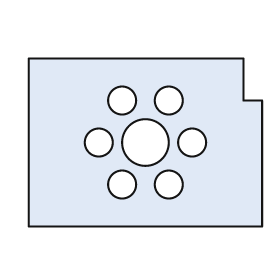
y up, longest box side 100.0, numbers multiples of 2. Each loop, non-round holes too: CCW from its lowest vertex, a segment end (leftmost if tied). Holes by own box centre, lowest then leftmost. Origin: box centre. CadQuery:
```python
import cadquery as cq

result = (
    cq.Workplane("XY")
    .moveTo(-50.0, -36.0)
    .lineTo(50.0, -36.0)
    .lineTo(50.0, 18.0)
    .lineTo(42.0, 18.0)
    .lineTo(42.0, 36.0)
    .lineTo(-50.0, 36.0)
    .close()
    .moveTo(-10.0, -18.0)
    .circle(6.0)
    .moveTo(10.0, -18.0)
    .circle(6.0)
    .moveTo(-20.0, 0.0)
    .circle(6.0)
    .moveTo(0.0, 0.0)
    .circle(10.0)
    .moveTo(20.0, 0.0)
    .circle(6.0)
    .moveTo(-10.0, 18.0)
    .circle(6.0)
    .moveTo(10.0, 18.0)
    .circle(6.0)
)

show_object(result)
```